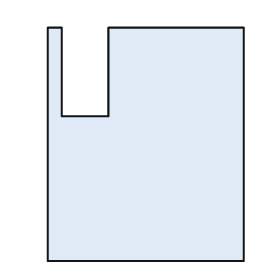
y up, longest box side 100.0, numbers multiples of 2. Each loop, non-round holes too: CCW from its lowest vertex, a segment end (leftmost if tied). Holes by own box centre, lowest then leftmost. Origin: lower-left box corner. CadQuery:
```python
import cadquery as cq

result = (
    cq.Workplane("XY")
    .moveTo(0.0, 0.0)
    .lineTo(84.0, 0.0)
    .lineTo(84.0, 100.0)
    .lineTo(26.0, 100.0)
    .lineTo(26.0, 62.0)
    .lineTo(6.0, 62.0)
    .lineTo(6.0, 100.0)
    .lineTo(0.0, 100.0)
    .close()
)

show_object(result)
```